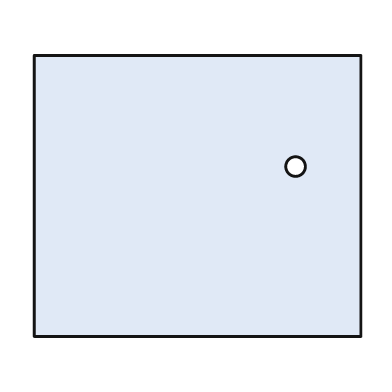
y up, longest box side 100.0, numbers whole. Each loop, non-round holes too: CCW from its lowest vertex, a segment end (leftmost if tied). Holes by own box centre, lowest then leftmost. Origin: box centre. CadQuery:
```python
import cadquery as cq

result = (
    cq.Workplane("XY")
    .moveTo(-50.0, -43.0)
    .lineTo(50.0, -43.0)
    .lineTo(50.0, 43.0)
    .lineTo(-50.0, 43.0)
    .close()
    .moveTo(30.0, 9.0)
    .circle(3.0)
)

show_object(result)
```